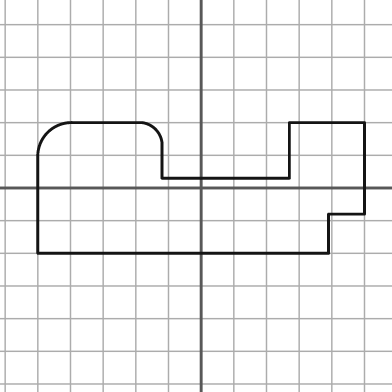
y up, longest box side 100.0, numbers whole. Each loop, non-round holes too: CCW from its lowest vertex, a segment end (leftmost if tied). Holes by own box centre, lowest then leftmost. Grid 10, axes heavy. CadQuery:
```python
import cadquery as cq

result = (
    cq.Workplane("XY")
    .moveTo(-50.0, -20.0)
    .lineTo(39.0, -20.0)
    .lineTo(39.0, -8.0)
    .lineTo(50.0, -8.0)
    .lineTo(50.0, 20.0)
    .lineTo(27.0, 20.0)
    .lineTo(27.0, 3.0)
    .lineTo(-12.0, 3.0)
    .lineTo(-12.0, 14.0)
    .threePointArc((-14.0, 18.0), (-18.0, 20.0))
    .lineTo(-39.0, 20.0)
    .threePointArc((-47.0, 17.0), (-50.0, 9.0))
    .close()
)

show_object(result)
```